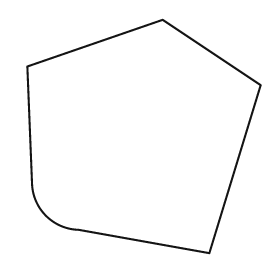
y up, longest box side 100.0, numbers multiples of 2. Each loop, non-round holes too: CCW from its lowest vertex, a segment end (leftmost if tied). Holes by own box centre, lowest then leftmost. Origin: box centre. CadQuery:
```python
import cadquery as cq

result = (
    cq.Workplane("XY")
    .moveTo(28.0, -50.0)
    .lineTo(50.0, 22.0)
    .lineTo(8.0, 50.0)
    .lineTo(-50.0, 30.0)
    .lineTo(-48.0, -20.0)
    .threePointArc((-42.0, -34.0), (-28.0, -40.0))
    .close()
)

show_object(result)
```